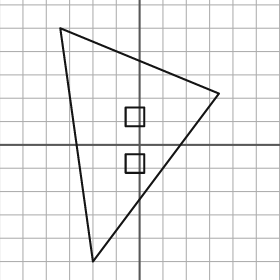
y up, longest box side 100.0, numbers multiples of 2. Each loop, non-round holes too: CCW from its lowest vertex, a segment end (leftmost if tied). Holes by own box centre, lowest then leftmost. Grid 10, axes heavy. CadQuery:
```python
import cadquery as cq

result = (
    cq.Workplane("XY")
    .moveTo(-20.0, -50.0)
    .lineTo(34.0, 22.0)
    .lineTo(-34.0, 50.0)
    .close()
    .moveTo(-6.0, -12.0)
    .lineTo(2.0, -12.0)
    .lineTo(2.0, -4.0)
    .lineTo(-6.0, -4.0)
    .close()
    .moveTo(-6.0, 8.0)
    .lineTo(2.0, 8.0)
    .lineTo(2.0, 16.0)
    .lineTo(-6.0, 16.0)
    .close()
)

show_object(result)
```